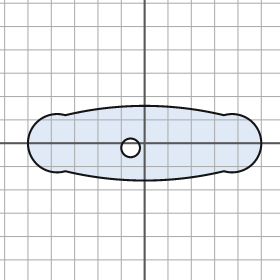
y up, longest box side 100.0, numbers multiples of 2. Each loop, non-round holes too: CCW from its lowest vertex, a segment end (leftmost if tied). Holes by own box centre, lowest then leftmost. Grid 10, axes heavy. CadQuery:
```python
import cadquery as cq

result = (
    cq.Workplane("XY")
    .moveTo(-34.0, -12.0)
    .threePointArc((0.0, -16.0), (34.0, -12.0))
    .threePointArc((50.0, 0.0), (34.0, 12.0))
    .threePointArc((0.0, 16.0), (-34.0, 12.0))
    .threePointArc((-50.0, 0.0), (-34.0, -12.0))
    .close()
    .moveTo(-6.0, -2.0)
    .circle(4.0)
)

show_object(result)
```